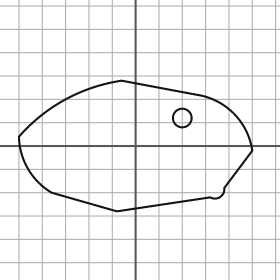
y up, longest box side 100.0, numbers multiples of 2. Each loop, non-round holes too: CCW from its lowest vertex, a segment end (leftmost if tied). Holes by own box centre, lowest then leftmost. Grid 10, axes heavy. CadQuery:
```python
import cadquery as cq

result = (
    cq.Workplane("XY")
    .moveTo(-8.0, -28.0)
    .lineTo(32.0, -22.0)
    .threePointArc((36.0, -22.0), (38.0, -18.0))
    .lineTo(50.0, -2.0)
    .threePointArc((42.0, 14.0), (26.0, 22.0))
    .lineTo(-6.0, 28.0)
    .threePointArc((-30.0, 20.0), (-50.0, 4.0))
    .threePointArc((-46.0, -10.0), (-36.0, -20.0))
    .close()
    .moveTo(20.0, 12.0)
    .circle(4.0)
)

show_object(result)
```